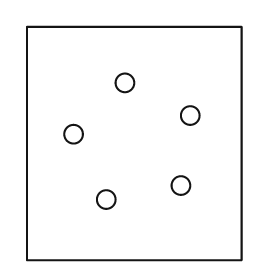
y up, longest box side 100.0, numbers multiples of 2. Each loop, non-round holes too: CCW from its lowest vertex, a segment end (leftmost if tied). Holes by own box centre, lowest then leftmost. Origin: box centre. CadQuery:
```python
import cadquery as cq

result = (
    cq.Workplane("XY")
    .moveTo(-46.0, -50.0)
    .lineTo(46.0, -50.0)
    .lineTo(46.0, 50.0)
    .lineTo(-46.0, 50.0)
    .close()
    .moveTo(-12.0, -24.0)
    .circle(4.0)
    .moveTo(20.0, -18.0)
    .circle(4.0)
    .moveTo(-26.0, 4.0)
    .circle(4.0)
    .moveTo(24.0, 12.0)
    .circle(4.0)
    .moveTo(-4.0, 26.0)
    .circle(4.0)
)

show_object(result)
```